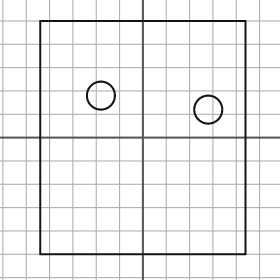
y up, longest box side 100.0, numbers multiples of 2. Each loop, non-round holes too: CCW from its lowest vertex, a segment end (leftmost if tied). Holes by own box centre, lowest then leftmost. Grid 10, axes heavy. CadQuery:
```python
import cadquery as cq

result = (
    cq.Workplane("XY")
    .moveTo(-44.0, -50.0)
    .lineTo(44.0, -50.0)
    .lineTo(44.0, 50.0)
    .lineTo(-44.0, 50.0)
    .close()
    .moveTo(28.0, 12.0)
    .circle(6.0)
    .moveTo(-18.0, 18.0)
    .circle(6.0)
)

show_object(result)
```